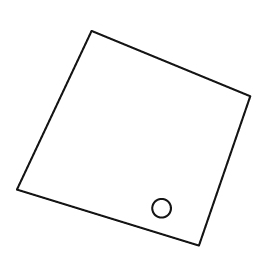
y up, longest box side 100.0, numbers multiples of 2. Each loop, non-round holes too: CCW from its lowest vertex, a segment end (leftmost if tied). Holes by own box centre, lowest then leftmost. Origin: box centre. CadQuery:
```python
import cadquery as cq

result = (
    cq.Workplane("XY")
    .moveTo(28.0, -46.0)
    .lineTo(50.0, 18.0)
    .lineTo(-18.0, 46.0)
    .lineTo(-50.0, -22.0)
    .close()
    .moveTo(12.0, -30.0)
    .circle(4.0)
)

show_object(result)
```